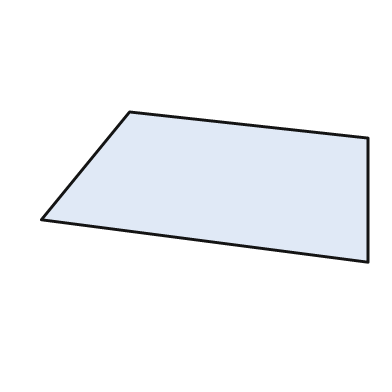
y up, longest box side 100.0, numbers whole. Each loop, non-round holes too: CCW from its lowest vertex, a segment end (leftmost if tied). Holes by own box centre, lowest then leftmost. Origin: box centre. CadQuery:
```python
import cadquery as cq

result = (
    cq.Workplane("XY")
    .moveTo(50.0, -23.0)
    .lineTo(50.0, 15.0)
    .lineTo(-23.0, 23.0)
    .lineTo(-50.0, -10.0)
    .close()
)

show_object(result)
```